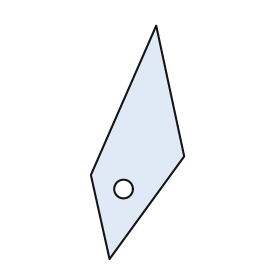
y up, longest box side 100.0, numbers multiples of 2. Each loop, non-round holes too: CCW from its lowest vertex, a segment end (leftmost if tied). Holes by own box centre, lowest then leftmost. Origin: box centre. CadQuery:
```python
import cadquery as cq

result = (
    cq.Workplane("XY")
    .moveTo(-12.0, -50.0)
    .lineTo(20.0, -6.0)
    .lineTo(8.0, 50.0)
    .lineTo(-20.0, -14.0)
    .close()
    .moveTo(-6.0, -20.0)
    .circle(4.0)
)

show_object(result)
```